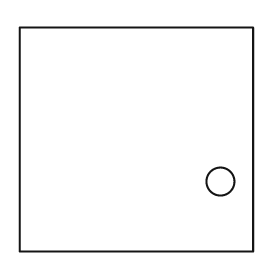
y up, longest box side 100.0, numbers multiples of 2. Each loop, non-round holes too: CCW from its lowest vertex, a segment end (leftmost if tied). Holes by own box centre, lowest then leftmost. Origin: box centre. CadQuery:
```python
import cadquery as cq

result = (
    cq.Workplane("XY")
    .moveTo(-50.0, -48.0)
    .lineTo(50.0, -48.0)
    .lineTo(50.0, 48.0)
    .lineTo(-50.0, 48.0)
    .close()
    .moveTo(36.0, -18.0)
    .circle(6.0)
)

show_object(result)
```